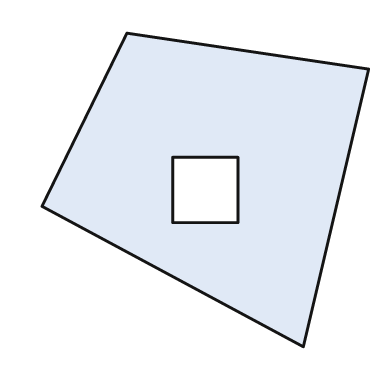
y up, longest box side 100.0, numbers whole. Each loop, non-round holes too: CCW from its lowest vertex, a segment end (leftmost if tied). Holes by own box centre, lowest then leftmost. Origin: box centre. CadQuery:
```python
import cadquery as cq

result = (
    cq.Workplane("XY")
    .moveTo(30.0, -48.0)
    .lineTo(50.0, 37.0)
    .lineTo(-24.0, 48.0)
    .lineTo(-50.0, -5.0)
    .close()
    .moveTo(-10.0, -10.0)
    .lineTo(10.0, -10.0)
    .lineTo(10.0, 10.0)
    .lineTo(-10.0, 10.0)
    .close()
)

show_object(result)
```